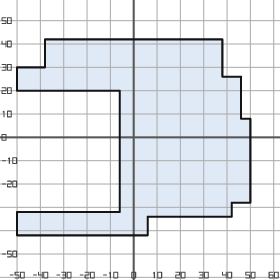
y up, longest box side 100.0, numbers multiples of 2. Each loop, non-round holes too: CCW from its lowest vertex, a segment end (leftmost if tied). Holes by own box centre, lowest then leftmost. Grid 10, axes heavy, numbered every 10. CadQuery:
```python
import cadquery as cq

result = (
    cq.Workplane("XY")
    .moveTo(-50.0, -42.0)
    .lineTo(6.0, -42.0)
    .lineTo(6.0, -34.0)
    .lineTo(42.0, -34.0)
    .lineTo(42.0, -28.0)
    .lineTo(50.0, -28.0)
    .lineTo(50.0, 8.0)
    .lineTo(46.0, 8.0)
    .lineTo(46.0, 26.0)
    .lineTo(38.0, 26.0)
    .lineTo(38.0, 42.0)
    .lineTo(-38.0, 42.0)
    .lineTo(-38.0, 30.0)
    .lineTo(-50.0, 30.0)
    .lineTo(-50.0, 20.0)
    .lineTo(-6.0, 20.0)
    .lineTo(-6.0, -32.0)
    .lineTo(-50.0, -32.0)
    .close()
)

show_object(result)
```